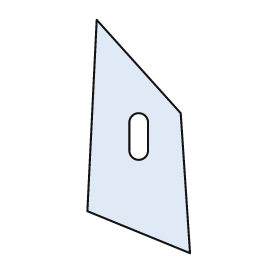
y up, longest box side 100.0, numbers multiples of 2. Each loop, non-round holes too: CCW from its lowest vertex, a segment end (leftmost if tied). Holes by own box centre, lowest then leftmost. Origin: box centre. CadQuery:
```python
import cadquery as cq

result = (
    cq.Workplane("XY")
    .moveTo(22.0, -50.0)
    .lineTo(18.0, 10.0)
    .lineTo(-18.0, 50.0)
    .lineTo(-22.0, -32.0)
    .close()
    .moveTo(-4.0, -6.0)
    .threePointArc((0.0, -10.0), (4.0, -6.0))
    .lineTo(4.0, 6.0)
    .threePointArc((0.0, 10.0), (-4.0, 6.0))
    .close()
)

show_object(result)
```